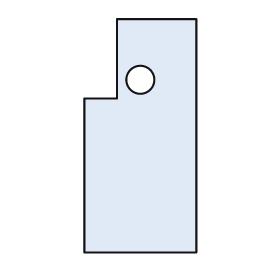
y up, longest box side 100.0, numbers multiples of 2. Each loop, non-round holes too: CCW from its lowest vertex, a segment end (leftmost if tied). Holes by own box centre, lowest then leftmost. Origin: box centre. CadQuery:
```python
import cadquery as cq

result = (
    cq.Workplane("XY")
    .moveTo(-24.0, -50.0)
    .lineTo(24.0, -50.0)
    .lineTo(24.0, 50.0)
    .lineTo(-10.0, 50.0)
    .lineTo(-10.0, 16.0)
    .lineTo(-24.0, 16.0)
    .close()
    .moveTo(0.0, 24.0)
    .circle(6.0)
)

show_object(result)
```